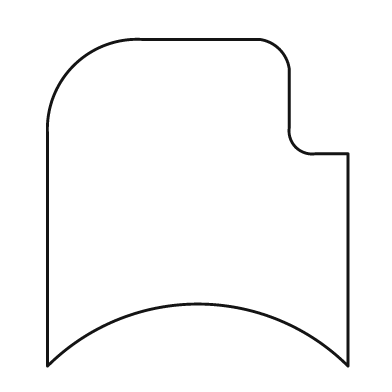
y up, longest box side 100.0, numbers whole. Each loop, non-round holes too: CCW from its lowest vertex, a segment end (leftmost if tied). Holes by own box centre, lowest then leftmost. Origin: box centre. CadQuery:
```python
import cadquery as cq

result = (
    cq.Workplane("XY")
    .moveTo(-46.0, -50.0)
    .threePointArc((0.0, -31.0), (46.0, -50.0))
    .lineTo(46.0, 15.0)
    .lineTo(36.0, 15.0)
    .threePointArc((30.0, 17.0), (28.0, 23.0))
    .lineTo(28.0, 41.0)
    .threePointArc((25.0, 47.0), (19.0, 50.0))
    .lineTo(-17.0, 50.0)
    .threePointArc((-38.0, 42.0), (-46.0, 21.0))
    .close()
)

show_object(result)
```